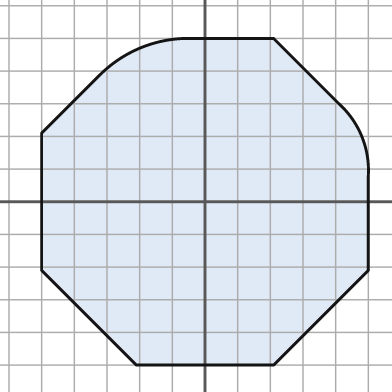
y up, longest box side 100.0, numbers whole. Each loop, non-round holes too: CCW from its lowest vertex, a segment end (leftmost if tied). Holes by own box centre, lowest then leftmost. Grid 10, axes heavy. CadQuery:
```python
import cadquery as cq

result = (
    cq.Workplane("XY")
    .moveTo(-21.0, -50.0)
    .lineTo(21.0, -50.0)
    .lineTo(50.0, -21.0)
    .lineTo(50.0, 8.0)
    .threePointArc((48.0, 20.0), (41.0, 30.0))
    .lineTo(21.0, 50.0)
    .lineTo(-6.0, 50.0)
    .threePointArc((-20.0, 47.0), (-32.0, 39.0))
    .lineTo(-50.0, 21.0)
    .lineTo(-50.0, -21.0)
    .close()
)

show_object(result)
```